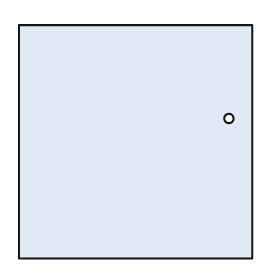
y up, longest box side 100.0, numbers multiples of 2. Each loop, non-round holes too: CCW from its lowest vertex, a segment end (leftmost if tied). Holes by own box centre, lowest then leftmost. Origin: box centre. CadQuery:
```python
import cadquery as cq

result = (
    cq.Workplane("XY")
    .moveTo(-50.0, -50.0)
    .lineTo(50.0, -50.0)
    .lineTo(50.0, 50.0)
    .lineTo(-50.0, 50.0)
    .close()
    .moveTo(40.0, 10.0)
    .circle(2.0)
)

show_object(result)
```